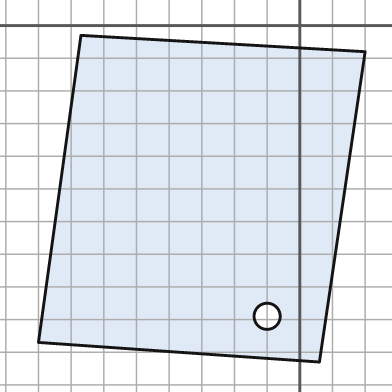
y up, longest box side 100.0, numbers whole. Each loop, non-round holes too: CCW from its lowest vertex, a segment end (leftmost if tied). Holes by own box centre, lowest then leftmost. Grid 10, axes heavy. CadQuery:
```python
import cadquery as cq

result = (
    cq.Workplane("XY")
    .moveTo(6.0, -103.0)
    .lineTo(20.0, -8.0)
    .lineTo(-67.0, -3.0)
    .lineTo(-80.0, -97.0)
    .close()
    .moveTo(-10.0, -89.0)
    .circle(4.0)
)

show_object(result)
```